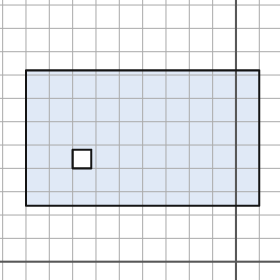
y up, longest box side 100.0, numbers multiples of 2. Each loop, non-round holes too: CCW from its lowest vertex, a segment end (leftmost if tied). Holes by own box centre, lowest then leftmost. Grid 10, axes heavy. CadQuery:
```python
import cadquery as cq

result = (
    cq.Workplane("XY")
    .moveTo(-90.0, 24.0)
    .lineTo(10.0, 24.0)
    .lineTo(10.0, 82.0)
    .lineTo(-90.0, 82.0)
    .close()
    .moveTo(-70.0, 40.0)
    .lineTo(-62.0, 40.0)
    .lineTo(-62.0, 48.0)
    .lineTo(-70.0, 48.0)
    .close()
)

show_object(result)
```